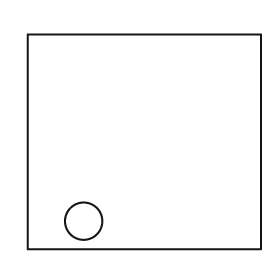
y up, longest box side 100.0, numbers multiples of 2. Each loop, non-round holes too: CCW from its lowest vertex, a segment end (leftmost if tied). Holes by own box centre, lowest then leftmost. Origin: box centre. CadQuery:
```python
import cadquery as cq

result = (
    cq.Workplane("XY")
    .moveTo(-50.0, -46.0)
    .lineTo(50.0, -46.0)
    .lineTo(50.0, 46.0)
    .lineTo(-50.0, 46.0)
    .close()
    .moveTo(-26.0, -34.0)
    .circle(8.0)
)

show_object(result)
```